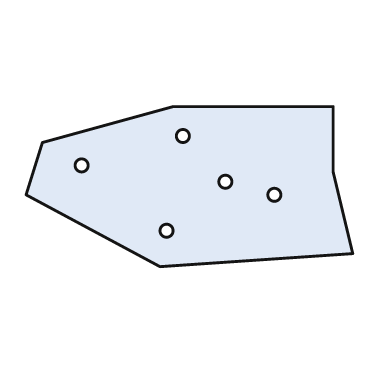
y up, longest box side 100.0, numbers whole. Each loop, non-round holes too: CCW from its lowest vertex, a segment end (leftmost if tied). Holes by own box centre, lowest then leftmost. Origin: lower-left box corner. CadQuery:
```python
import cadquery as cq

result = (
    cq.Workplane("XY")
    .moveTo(41.0, 0.0)
    .lineTo(100.0, 4.0)
    .lineTo(94.0, 29.0)
    .lineTo(94.0, 49.0)
    .lineTo(45.0, 49.0)
    .lineTo(5.0, 38.0)
    .lineTo(0.0, 22.0)
    .close()
    .moveTo(43.0, 11.0)
    .circle(2.0)
    .moveTo(76.0, 22.0)
    .circle(2.0)
    .moveTo(61.0, 26.0)
    .circle(2.0)
    .moveTo(17.0, 31.0)
    .circle(2.0)
    .moveTo(48.0, 40.0)
    .circle(2.0)
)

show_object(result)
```